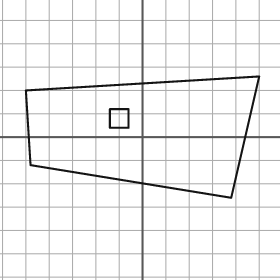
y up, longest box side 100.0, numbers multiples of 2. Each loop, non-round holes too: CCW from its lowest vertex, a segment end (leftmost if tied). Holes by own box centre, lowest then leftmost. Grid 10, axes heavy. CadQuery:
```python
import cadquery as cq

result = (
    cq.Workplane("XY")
    .moveTo(38.0, -26.0)
    .lineTo(50.0, 26.0)
    .lineTo(-50.0, 20.0)
    .lineTo(-48.0, -12.0)
    .close()
    .moveTo(-14.0, 4.0)
    .lineTo(-6.0, 4.0)
    .lineTo(-6.0, 12.0)
    .lineTo(-14.0, 12.0)
    .close()
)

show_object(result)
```